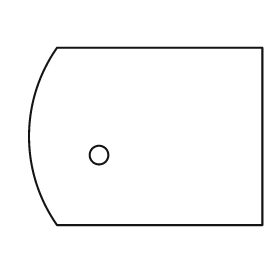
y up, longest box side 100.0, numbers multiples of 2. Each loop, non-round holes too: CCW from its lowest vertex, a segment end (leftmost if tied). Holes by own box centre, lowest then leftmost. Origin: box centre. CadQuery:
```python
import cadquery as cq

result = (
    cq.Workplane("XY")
    .moveTo(-38.0, -38.0)
    .lineTo(50.0, -38.0)
    .lineTo(50.0, 38.0)
    .lineTo(-38.0, 38.0)
    .threePointArc((-50.0, 0.0), (-38.0, -38.0))
    .close()
    .moveTo(-20.0, -8.0)
    .circle(4.0)
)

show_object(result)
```